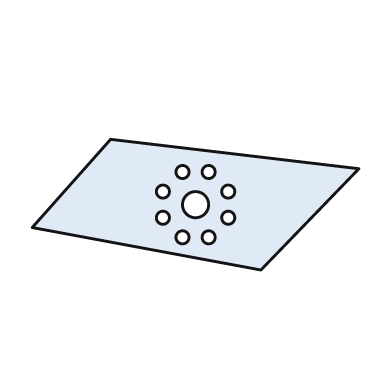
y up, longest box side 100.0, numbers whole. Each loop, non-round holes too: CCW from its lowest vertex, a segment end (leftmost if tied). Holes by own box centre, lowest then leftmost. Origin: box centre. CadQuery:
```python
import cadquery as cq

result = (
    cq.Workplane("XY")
    .moveTo(20.0, -20.0)
    .lineTo(50.0, 11.0)
    .lineTo(-26.0, 20.0)
    .lineTo(-50.0, -7.0)
    .close()
    .moveTo(-4.0, -10.0)
    .circle(2.0)
    .moveTo(4.0, -10.0)
    .circle(2.0)
    .moveTo(-10.0, -4.0)
    .circle(2.0)
    .moveTo(10.0, -4.0)
    .circle(2.0)
    .moveTo(0.0, 0.0)
    .circle(4.0)
    .moveTo(-10.0, 4.0)
    .circle(2.0)
    .moveTo(10.0, 4.0)
    .circle(2.0)
    .moveTo(-4.0, 10.0)
    .circle(2.0)
    .moveTo(4.0, 10.0)
    .circle(2.0)
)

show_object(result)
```